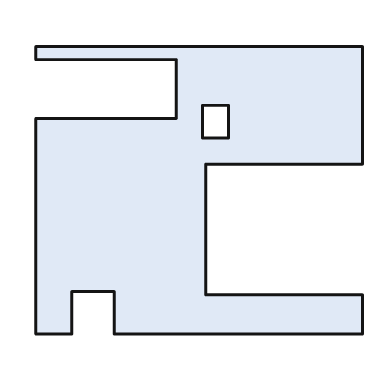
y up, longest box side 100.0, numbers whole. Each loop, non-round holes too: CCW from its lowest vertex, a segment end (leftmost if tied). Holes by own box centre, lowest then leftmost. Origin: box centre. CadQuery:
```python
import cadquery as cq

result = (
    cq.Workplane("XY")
    .moveTo(-50.0, -44.0)
    .lineTo(-39.0, -44.0)
    .lineTo(-39.0, -31.0)
    .lineTo(-26.0, -31.0)
    .lineTo(-26.0, -44.0)
    .lineTo(50.0, -44.0)
    .lineTo(50.0, -32.0)
    .lineTo(2.0, -32.0)
    .lineTo(2.0, 8.0)
    .lineTo(50.0, 8.0)
    .lineTo(50.0, 44.0)
    .lineTo(-50.0, 44.0)
    .lineTo(-50.0, 40.0)
    .lineTo(-7.0, 40.0)
    .lineTo(-7.0, 22.0)
    .lineTo(-50.0, 22.0)
    .close()
    .moveTo(1.0, 16.0)
    .lineTo(9.0, 16.0)
    .lineTo(9.0, 26.0)
    .lineTo(1.0, 26.0)
    .close()
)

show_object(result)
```